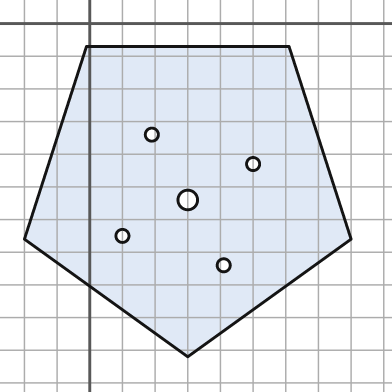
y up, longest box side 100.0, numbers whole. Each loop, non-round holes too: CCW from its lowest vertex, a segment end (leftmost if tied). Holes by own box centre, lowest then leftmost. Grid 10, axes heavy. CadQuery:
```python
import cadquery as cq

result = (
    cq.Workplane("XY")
    .moveTo(30.0, -102.0)
    .lineTo(80.0, -66.0)
    .lineTo(61.0, -7.0)
    .lineTo(-1.0, -7.0)
    .lineTo(-20.0, -66.0)
    .close()
    .moveTo(41.0, -74.0)
    .circle(2.0)
    .moveTo(10.0, -65.0)
    .circle(2.0)
    .moveTo(30.0, -54.0)
    .circle(3.0)
    .moveTo(50.0, -43.0)
    .circle(2.0)
    .moveTo(19.0, -34.0)
    .circle(2.0)
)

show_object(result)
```